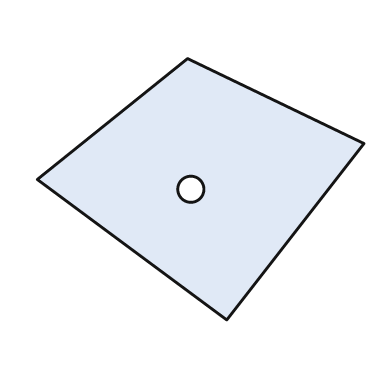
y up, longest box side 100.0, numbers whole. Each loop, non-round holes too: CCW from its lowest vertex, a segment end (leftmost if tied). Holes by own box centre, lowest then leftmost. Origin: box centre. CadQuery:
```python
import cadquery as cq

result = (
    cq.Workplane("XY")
    .moveTo(8.0, -40.0)
    .lineTo(50.0, 14.0)
    .lineTo(-4.0, 40.0)
    .lineTo(-50.0, 3.0)
    .close()
    .moveTo(-3.0, 0.0)
    .circle(4.0)
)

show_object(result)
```